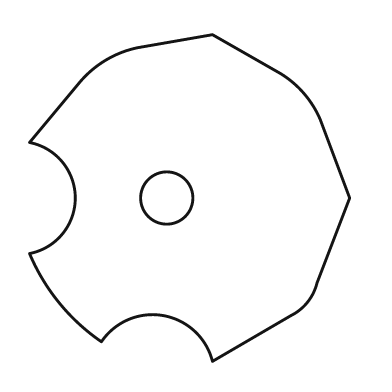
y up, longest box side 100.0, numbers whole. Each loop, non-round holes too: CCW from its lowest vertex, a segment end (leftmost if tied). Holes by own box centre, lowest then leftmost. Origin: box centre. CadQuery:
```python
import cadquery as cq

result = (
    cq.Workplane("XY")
    .moveTo(7.0, -50.0)
    .lineTo(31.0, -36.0)
    .threePointArc((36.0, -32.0), (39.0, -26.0))
    .lineTo(49.0, 0.0)
    .lineTo(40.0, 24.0)
    .threePointArc((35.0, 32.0), (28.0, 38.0))
    .lineTo(7.0, 50.0)
    .lineTo(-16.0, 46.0)
    .threePointArc((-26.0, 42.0), (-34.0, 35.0))
    .lineTo(-49.0, 17.0)
    .threePointArc((-35.0, 0.0), (-49.0, -17.0))
    .threePointArc((-40.0, -32.0), (-27.0, -44.0))
    .threePointArc((-8.0, -36.0), (7.0, -50.0))
    .close()
    .moveTo(-7.0, 0.0)
    .circle(8.0)
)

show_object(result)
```